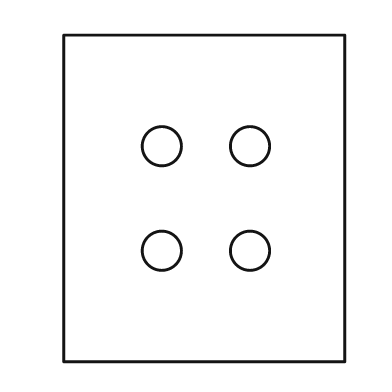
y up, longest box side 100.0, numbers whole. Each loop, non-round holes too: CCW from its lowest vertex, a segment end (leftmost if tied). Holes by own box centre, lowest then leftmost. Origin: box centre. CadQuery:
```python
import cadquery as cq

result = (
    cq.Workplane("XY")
    .moveTo(-43.0, -50.0)
    .lineTo(43.0, -50.0)
    .lineTo(43.0, 50.0)
    .lineTo(-43.0, 50.0)
    .close()
    .moveTo(-13.0, -16.0)
    .circle(6.0)
    .moveTo(14.0, -16.0)
    .circle(6.0)
    .moveTo(-13.0, 16.0)
    .circle(6.0)
    .moveTo(14.0, 16.0)
    .circle(6.0)
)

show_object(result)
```